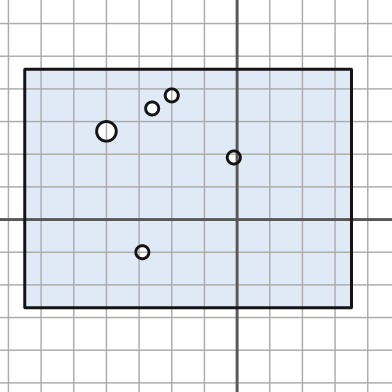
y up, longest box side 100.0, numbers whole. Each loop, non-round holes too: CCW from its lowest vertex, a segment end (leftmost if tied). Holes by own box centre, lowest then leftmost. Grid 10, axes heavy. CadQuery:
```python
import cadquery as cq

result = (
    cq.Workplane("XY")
    .moveTo(-65.0, -27.0)
    .lineTo(35.0, -27.0)
    .lineTo(35.0, 46.0)
    .lineTo(-65.0, 46.0)
    .close()
    .moveTo(-29.0, -10.0)
    .circle(2.0)
    .moveTo(-1.0, 19.0)
    .circle(2.0)
    .moveTo(-40.0, 27.0)
    .circle(3.0)
    .moveTo(-26.0, 34.0)
    .circle(2.0)
    .moveTo(-20.0, 38.0)
    .circle(2.0)
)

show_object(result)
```